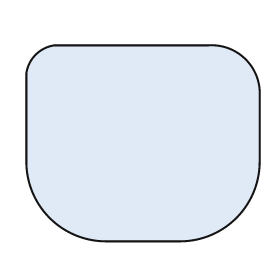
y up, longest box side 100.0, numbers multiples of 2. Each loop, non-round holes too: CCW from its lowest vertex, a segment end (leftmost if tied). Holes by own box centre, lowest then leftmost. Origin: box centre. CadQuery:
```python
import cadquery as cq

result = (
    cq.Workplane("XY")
    .moveTo(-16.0, -42.0)
    .lineTo(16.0, -42.0)
    .threePointArc((40.0, -32.0), (50.0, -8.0))
    .lineTo(50.0, 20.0)
    .threePointArc((44.0, 36.0), (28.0, 42.0))
    .lineTo(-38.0, 42.0)
    .threePointArc((-46.0, 38.0), (-50.0, 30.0))
    .lineTo(-50.0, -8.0)
    .threePointArc((-40.0, -32.0), (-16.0, -42.0))
    .close()
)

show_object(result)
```